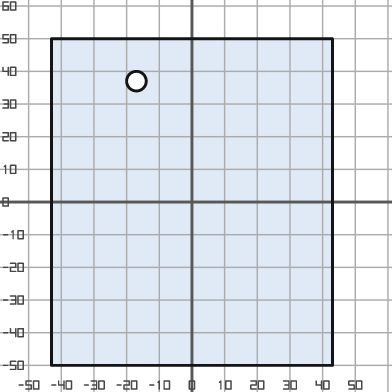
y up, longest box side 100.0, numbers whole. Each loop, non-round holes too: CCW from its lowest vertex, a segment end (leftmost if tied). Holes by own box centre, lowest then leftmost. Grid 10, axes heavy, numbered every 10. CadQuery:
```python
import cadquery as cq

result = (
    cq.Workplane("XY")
    .moveTo(-43.0, -50.0)
    .lineTo(43.0, -50.0)
    .lineTo(43.0, 50.0)
    .lineTo(-43.0, 50.0)
    .close()
    .moveTo(-17.0, 37.0)
    .circle(3.0)
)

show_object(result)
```